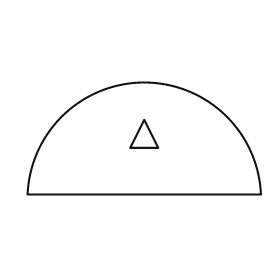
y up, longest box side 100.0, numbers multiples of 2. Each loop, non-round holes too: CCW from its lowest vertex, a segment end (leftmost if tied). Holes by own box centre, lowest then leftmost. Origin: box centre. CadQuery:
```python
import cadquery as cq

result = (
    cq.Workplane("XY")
    .moveTo(-50.0, -24.0)
    .lineTo(50.0, -24.0)
    .threePointArc((0.0, 24.0), (-50.0, -24.0))
    .close()
    .moveTo(-6.0, -4.0)
    .lineTo(6.0, -4.0)
    .lineTo(0.0, 8.0)
    .close()
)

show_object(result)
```